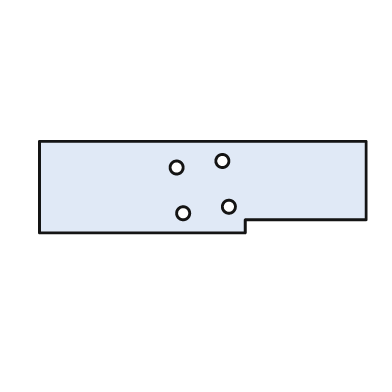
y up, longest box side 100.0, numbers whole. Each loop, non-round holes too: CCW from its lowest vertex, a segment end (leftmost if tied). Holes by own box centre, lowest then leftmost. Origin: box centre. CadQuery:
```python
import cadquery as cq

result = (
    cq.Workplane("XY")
    .moveTo(-50.0, -14.0)
    .lineTo(13.0, -14.0)
    .lineTo(13.0, -10.0)
    .lineTo(50.0, -10.0)
    .lineTo(50.0, 14.0)
    .lineTo(-50.0, 14.0)
    .close()
    .moveTo(-6.0, -8.0)
    .circle(2.0)
    .moveTo(8.0, -6.0)
    .circle(2.0)
    .moveTo(-8.0, 6.0)
    .circle(2.0)
    .moveTo(6.0, 8.0)
    .circle(2.0)
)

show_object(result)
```